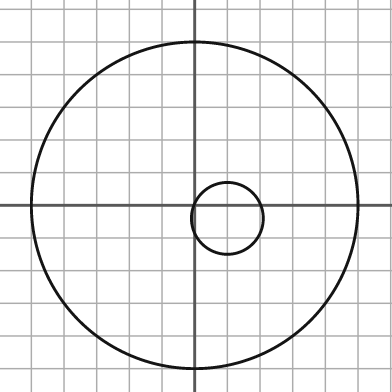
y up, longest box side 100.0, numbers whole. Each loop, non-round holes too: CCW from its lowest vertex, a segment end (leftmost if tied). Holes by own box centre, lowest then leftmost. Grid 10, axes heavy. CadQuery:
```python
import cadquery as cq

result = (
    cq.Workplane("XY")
    .moveTo(0.0, 0.0)
    .circle(50.0)
    .moveTo(10.0, -4.0)
    .circle(11.0)
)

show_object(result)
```